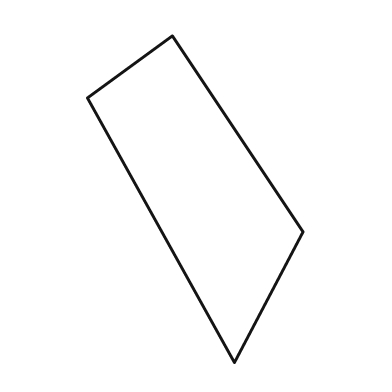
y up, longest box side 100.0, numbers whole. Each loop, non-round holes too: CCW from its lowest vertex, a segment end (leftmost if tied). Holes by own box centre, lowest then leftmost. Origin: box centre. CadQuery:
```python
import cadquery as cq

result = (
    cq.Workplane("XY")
    .moveTo(12.0, -50.0)
    .lineTo(33.0, -10.0)
    .lineTo(-7.0, 50.0)
    .lineTo(-33.0, 31.0)
    .close()
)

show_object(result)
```